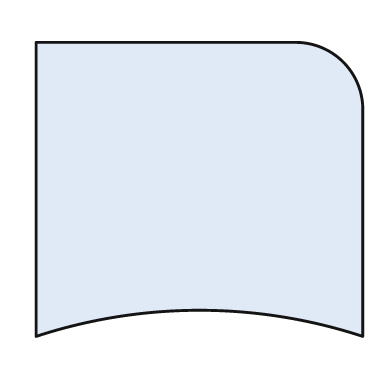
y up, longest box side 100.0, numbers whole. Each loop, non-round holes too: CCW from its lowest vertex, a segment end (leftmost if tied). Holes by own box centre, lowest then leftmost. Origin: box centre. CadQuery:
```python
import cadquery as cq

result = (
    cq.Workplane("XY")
    .moveTo(-50.0, -45.0)
    .threePointArc((0.0, -37.0), (50.0, -45.0))
    .lineTo(50.0, 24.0)
    .threePointArc((44.0, 39.0), (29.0, 45.0))
    .lineTo(-50.0, 45.0)
    .close()
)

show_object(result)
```